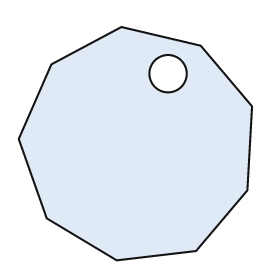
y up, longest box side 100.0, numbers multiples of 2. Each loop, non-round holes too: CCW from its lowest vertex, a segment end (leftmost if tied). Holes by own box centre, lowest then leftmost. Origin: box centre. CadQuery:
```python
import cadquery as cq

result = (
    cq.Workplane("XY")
    .moveTo(-8.0, -50.0)
    .lineTo(26.0, -46.0)
    .lineTo(48.0, -20.0)
    .lineTo(50.0, 16.0)
    .lineTo(28.0, 42.0)
    .lineTo(-6.0, 50.0)
    .lineTo(-36.0, 34.0)
    .lineTo(-50.0, 2.0)
    .lineTo(-38.0, -32.0)
    .close()
    .moveTo(14.0, 30.0)
    .circle(8.0)
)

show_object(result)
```